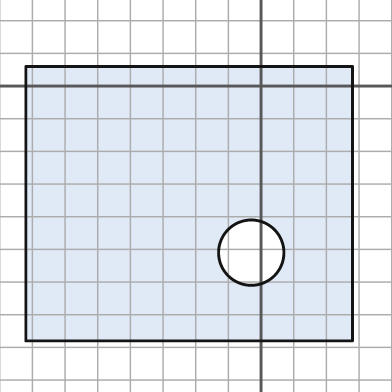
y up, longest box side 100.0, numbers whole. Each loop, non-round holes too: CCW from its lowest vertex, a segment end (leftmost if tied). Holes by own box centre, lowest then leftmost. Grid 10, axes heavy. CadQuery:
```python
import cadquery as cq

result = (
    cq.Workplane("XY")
    .moveTo(-72.0, -78.0)
    .lineTo(28.0, -78.0)
    .lineTo(28.0, 6.0)
    .lineTo(-72.0, 6.0)
    .close()
    .moveTo(-3.0, -51.0)
    .circle(10.0)
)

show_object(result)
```